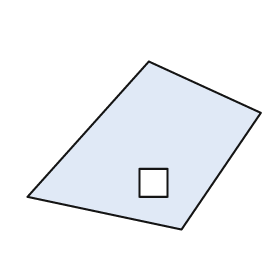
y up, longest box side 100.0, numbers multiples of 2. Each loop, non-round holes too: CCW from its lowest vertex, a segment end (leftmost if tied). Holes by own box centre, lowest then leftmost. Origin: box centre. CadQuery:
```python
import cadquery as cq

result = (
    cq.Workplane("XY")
    .moveTo(16.0, -36.0)
    .lineTo(50.0, 14.0)
    .lineTo(2.0, 36.0)
    .lineTo(-50.0, -22.0)
    .close()
    .moveTo(-2.0, -22.0)
    .lineTo(10.0, -22.0)
    .lineTo(10.0, -10.0)
    .lineTo(-2.0, -10.0)
    .close()
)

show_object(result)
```